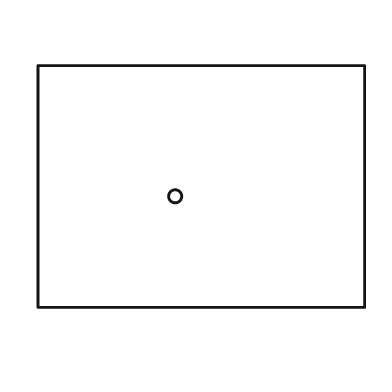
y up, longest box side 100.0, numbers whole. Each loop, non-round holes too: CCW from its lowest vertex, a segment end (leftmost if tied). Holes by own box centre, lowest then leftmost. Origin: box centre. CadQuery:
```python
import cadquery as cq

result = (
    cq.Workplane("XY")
    .moveTo(-50.0, -37.0)
    .lineTo(50.0, -37.0)
    .lineTo(50.0, 37.0)
    .lineTo(-50.0, 37.0)
    .close()
    .moveTo(-8.0, -3.0)
    .circle(2.0)
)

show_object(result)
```